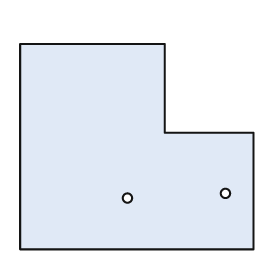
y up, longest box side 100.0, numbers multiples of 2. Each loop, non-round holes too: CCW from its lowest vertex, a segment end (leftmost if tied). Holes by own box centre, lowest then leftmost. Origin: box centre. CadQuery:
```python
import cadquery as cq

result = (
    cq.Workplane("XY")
    .moveTo(-50.0, -44.0)
    .lineTo(50.0, -44.0)
    .lineTo(50.0, 6.0)
    .lineTo(12.0, 6.0)
    .lineTo(12.0, 44.0)
    .lineTo(-50.0, 44.0)
    .close()
    .moveTo(-4.0, -22.0)
    .circle(2.0)
    .moveTo(38.0, -20.0)
    .circle(2.0)
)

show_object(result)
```